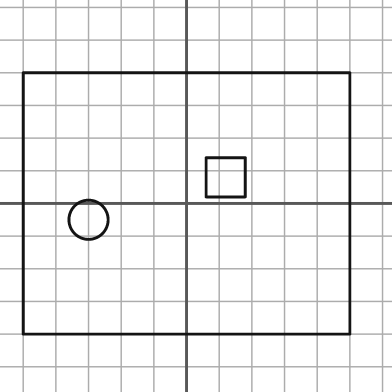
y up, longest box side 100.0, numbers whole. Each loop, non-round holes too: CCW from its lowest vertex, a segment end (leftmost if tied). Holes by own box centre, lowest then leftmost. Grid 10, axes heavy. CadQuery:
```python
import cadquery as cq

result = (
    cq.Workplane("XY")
    .moveTo(-50.0, -40.0)
    .lineTo(50.0, -40.0)
    .lineTo(50.0, 40.0)
    .lineTo(-50.0, 40.0)
    .close()
    .moveTo(-30.0, -5.0)
    .circle(6.0)
    .moveTo(6.0, 2.0)
    .lineTo(18.0, 2.0)
    .lineTo(18.0, 14.0)
    .lineTo(6.0, 14.0)
    .close()
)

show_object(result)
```